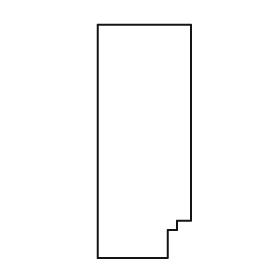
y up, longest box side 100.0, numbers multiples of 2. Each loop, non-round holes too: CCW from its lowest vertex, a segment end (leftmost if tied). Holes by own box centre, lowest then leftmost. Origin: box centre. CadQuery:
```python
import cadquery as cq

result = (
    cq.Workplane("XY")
    .moveTo(-20.0, -50.0)
    .lineTo(10.0, -50.0)
    .lineTo(10.0, -38.0)
    .lineTo(14.0, -38.0)
    .lineTo(14.0, -34.0)
    .lineTo(20.0, -34.0)
    .lineTo(20.0, 50.0)
    .lineTo(-20.0, 50.0)
    .close()
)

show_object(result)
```